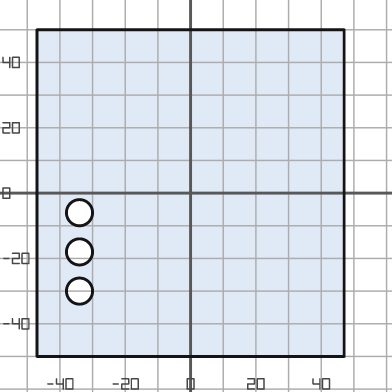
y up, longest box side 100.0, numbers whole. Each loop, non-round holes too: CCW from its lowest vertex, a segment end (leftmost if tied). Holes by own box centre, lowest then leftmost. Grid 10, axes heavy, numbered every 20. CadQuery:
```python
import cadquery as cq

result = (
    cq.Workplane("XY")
    .moveTo(-47.0, -50.0)
    .lineTo(47.0, -50.0)
    .lineTo(47.0, 50.0)
    .lineTo(-47.0, 50.0)
    .close()
    .moveTo(-34.0, -30.0)
    .circle(4.0)
    .moveTo(-34.0, -18.0)
    .circle(4.0)
    .moveTo(-34.0, -6.0)
    .circle(4.0)
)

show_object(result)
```